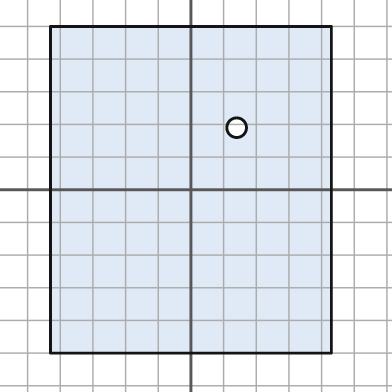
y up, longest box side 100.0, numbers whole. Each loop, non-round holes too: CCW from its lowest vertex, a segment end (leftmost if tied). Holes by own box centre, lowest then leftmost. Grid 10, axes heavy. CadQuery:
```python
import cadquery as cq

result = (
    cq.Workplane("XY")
    .moveTo(-43.0, -50.0)
    .lineTo(43.0, -50.0)
    .lineTo(43.0, 50.0)
    .lineTo(-43.0, 50.0)
    .close()
    .moveTo(14.0, 19.0)
    .circle(3.0)
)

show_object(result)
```